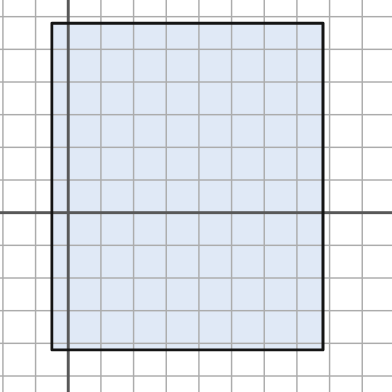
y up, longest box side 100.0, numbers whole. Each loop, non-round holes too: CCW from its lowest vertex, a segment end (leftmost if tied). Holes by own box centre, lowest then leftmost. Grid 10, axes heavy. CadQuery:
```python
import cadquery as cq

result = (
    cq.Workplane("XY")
    .moveTo(-5.0, -42.0)
    .lineTo(78.0, -42.0)
    .lineTo(78.0, 58.0)
    .lineTo(-5.0, 58.0)
    .close()
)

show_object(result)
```